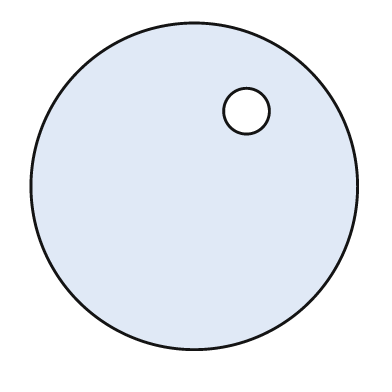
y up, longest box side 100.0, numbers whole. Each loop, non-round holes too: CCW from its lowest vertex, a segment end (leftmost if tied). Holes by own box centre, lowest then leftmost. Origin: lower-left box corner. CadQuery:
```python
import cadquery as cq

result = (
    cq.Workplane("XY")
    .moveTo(50.0, 50.0)
    .circle(50.0)
    .moveTo(66.0, 73.0)
    .circle(7.0)
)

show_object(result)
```